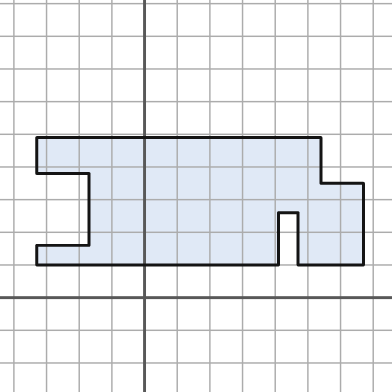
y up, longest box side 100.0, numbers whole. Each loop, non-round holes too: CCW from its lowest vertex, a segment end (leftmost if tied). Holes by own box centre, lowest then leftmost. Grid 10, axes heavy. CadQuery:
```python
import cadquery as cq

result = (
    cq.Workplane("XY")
    .moveTo(-33.0, 10.0)
    .lineTo(41.0, 10.0)
    .lineTo(41.0, 26.0)
    .lineTo(47.0, 26.0)
    .lineTo(47.0, 10.0)
    .lineTo(67.0, 10.0)
    .lineTo(67.0, 35.0)
    .lineTo(54.0, 35.0)
    .lineTo(54.0, 49.0)
    .lineTo(-33.0, 49.0)
    .lineTo(-33.0, 38.0)
    .lineTo(-17.0, 38.0)
    .lineTo(-17.0, 16.0)
    .lineTo(-33.0, 16.0)
    .close()
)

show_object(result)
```